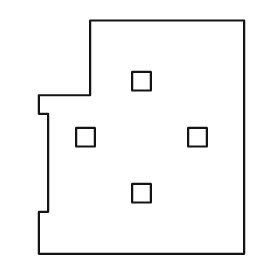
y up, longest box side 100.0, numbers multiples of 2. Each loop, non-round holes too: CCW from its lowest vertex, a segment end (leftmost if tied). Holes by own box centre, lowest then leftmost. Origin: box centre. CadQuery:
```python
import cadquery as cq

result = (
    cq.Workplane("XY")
    .moveTo(-44.0, -50.0)
    .lineTo(44.0, -50.0)
    .lineTo(44.0, 50.0)
    .lineTo(-22.0, 50.0)
    .lineTo(-22.0, 18.0)
    .lineTo(-44.0, 18.0)
    .lineTo(-44.0, 10.0)
    .lineTo(-40.0, 10.0)
    .lineTo(-40.0, -32.0)
    .lineTo(-44.0, -32.0)
    .close()
    .moveTo(-4.0, -28.0)
    .lineTo(4.0, -28.0)
    .lineTo(4.0, -20.0)
    .lineTo(-4.0, -20.0)
    .close()
    .moveTo(-28.0, -4.0)
    .lineTo(-20.0, -4.0)
    .lineTo(-20.0, 4.0)
    .lineTo(-28.0, 4.0)
    .close()
    .moveTo(20.0, -4.0)
    .lineTo(28.0, -4.0)
    .lineTo(28.0, 4.0)
    .lineTo(20.0, 4.0)
    .close()
    .moveTo(-4.0, 20.0)
    .lineTo(4.0, 20.0)
    .lineTo(4.0, 28.0)
    .lineTo(-4.0, 28.0)
    .close()
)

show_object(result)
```